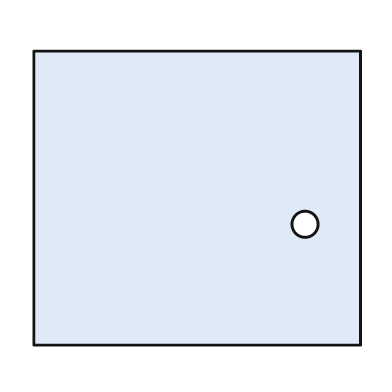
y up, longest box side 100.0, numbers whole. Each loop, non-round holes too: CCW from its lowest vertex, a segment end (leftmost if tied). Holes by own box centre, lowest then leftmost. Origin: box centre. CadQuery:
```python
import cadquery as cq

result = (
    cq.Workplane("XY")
    .moveTo(-50.0, -45.0)
    .lineTo(50.0, -45.0)
    .lineTo(50.0, 45.0)
    .lineTo(-50.0, 45.0)
    .close()
    .moveTo(33.0, -8.0)
    .circle(4.0)
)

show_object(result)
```